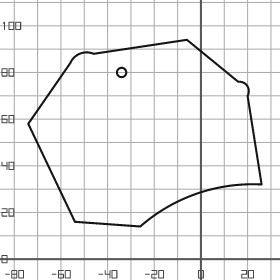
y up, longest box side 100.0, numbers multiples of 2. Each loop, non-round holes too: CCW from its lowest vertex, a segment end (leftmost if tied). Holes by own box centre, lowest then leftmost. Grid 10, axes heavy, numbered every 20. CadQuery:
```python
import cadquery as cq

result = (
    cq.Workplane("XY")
    .moveTo(-26.0, 14.0)
    .threePointArc((-2.0, 28.0), (26.0, 32.0))
    .lineTo(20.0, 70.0)
    .threePointArc((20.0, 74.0), (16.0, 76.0))
    .lineTo(-6.0, 94.0)
    .lineTo(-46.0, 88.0)
    .threePointArc((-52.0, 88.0), (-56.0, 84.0))
    .lineTo(-74.0, 58.0)
    .lineTo(-54.0, 16.0)
    .close()
    .moveTo(-34.0, 80.0)
    .circle(2.0)
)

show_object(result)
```